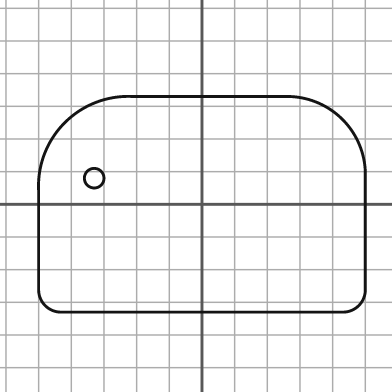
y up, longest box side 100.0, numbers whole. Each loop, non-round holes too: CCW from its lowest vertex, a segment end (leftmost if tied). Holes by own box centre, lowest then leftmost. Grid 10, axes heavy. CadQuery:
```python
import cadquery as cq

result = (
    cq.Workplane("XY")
    .moveTo(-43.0, -33.0)
    .lineTo(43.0, -33.0)
    .threePointArc((48.0, -31.0), (50.0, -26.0))
    .lineTo(50.0, 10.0)
    .threePointArc((43.0, 26.0), (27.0, 33.0))
    .lineTo(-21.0, 33.0)
    .threePointArc((-42.0, 25.0), (-50.0, 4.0))
    .lineTo(-50.0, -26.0)
    .threePointArc((-48.0, -31.0), (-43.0, -33.0))
    .close()
    .moveTo(-33.0, 8.0)
    .circle(3.0)
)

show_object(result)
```